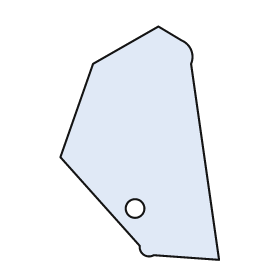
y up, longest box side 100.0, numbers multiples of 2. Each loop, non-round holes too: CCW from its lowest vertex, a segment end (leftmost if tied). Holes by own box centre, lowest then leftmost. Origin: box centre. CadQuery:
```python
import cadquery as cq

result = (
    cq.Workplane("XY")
    .moveTo(34.0, -50.0)
    .lineTo(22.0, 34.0)
    .threePointArc((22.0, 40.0), (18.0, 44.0))
    .lineTo(8.0, 50.0)
    .lineTo(-20.0, 34.0)
    .lineTo(-34.0, -6.0)
    .lineTo(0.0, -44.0)
    .threePointArc((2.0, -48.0), (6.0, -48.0))
    .close()
    .moveTo(-2.0, -28.0)
    .circle(4.0)
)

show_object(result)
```